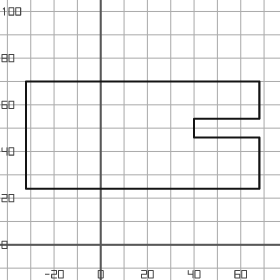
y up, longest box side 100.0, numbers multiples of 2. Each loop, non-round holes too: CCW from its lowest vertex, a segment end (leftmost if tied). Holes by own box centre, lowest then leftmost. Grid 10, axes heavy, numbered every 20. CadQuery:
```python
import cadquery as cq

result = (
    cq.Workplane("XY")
    .moveTo(-32.0, 24.0)
    .lineTo(68.0, 24.0)
    .lineTo(68.0, 46.0)
    .lineTo(40.0, 46.0)
    .lineTo(40.0, 54.0)
    .lineTo(68.0, 54.0)
    .lineTo(68.0, 70.0)
    .lineTo(-32.0, 70.0)
    .close()
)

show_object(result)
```